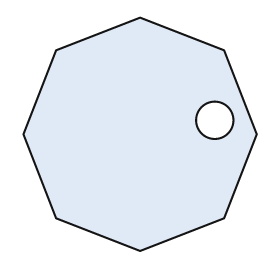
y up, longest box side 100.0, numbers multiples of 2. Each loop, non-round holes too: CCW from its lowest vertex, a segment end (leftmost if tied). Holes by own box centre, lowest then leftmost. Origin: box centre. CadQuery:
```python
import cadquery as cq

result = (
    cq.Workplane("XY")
    .moveTo(0.0, -50.0)
    .lineTo(36.0, -36.0)
    .lineTo(50.0, 0.0)
    .lineTo(36.0, 36.0)
    .lineTo(0.0, 50.0)
    .lineTo(-36.0, 36.0)
    .lineTo(-50.0, 0.0)
    .lineTo(-36.0, -36.0)
    .close()
    .moveTo(32.0, 6.0)
    .circle(8.0)
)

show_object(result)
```